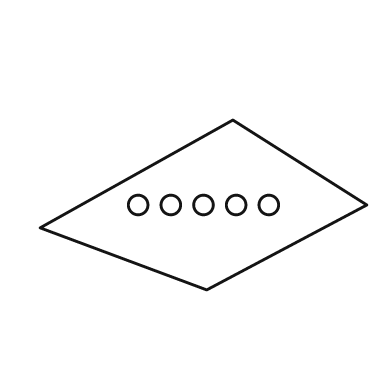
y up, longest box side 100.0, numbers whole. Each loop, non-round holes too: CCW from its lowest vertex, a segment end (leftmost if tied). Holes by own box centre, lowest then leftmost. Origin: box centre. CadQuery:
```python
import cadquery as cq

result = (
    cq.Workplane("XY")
    .moveTo(1.0, -26.0)
    .lineTo(50.0, 0.0)
    .lineTo(9.0, 26.0)
    .lineTo(-50.0, -7.0)
    .close()
    .moveTo(-20.0, 0.0)
    .circle(3.0)
    .moveTo(-10.0, 0.0)
    .circle(3.0)
    .moveTo(0.0, 0.0)
    .circle(3.0)
    .moveTo(10.0, 0.0)
    .circle(3.0)
    .moveTo(20.0, 0.0)
    .circle(3.0)
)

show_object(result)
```